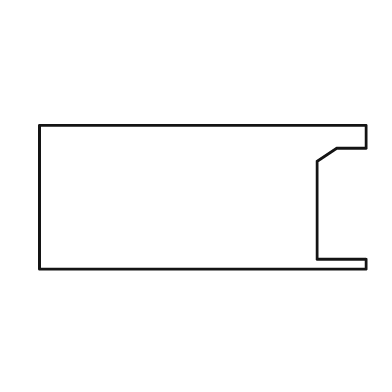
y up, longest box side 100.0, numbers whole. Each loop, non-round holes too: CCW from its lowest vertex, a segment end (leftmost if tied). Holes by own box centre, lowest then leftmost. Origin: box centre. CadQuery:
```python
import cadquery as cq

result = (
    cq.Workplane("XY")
    .moveTo(-50.0, -22.0)
    .lineTo(50.0, -22.0)
    .lineTo(50.0, -19.0)
    .lineTo(35.0, -19.0)
    .lineTo(35.0, 11.0)
    .lineTo(41.0, 15.0)
    .lineTo(50.0, 15.0)
    .lineTo(50.0, 22.0)
    .lineTo(-50.0, 22.0)
    .close()
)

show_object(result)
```